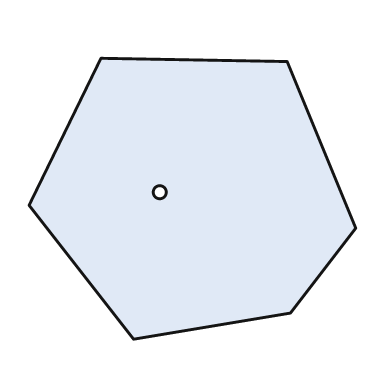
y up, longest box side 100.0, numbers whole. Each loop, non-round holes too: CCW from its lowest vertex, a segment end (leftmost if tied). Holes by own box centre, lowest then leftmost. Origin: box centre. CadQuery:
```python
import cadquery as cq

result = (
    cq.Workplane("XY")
    .moveTo(-18.0, -43.0)
    .lineTo(30.0, -35.0)
    .lineTo(50.0, -9.0)
    .lineTo(29.0, 42.0)
    .lineTo(-28.0, 43.0)
    .lineTo(-50.0, -2.0)
    .close()
    .moveTo(-10.0, 2.0)
    .circle(2.0)
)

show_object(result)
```